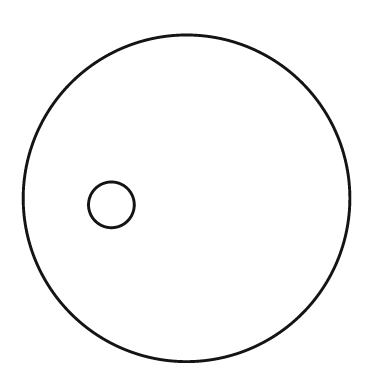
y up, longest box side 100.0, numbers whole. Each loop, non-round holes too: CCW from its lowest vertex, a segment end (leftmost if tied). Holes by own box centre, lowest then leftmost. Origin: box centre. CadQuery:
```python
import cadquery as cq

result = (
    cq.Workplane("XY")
    .moveTo(0.0, 0.0)
    .circle(50.0)
    .moveTo(-23.0, -2.0)
    .circle(7.0)
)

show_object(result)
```